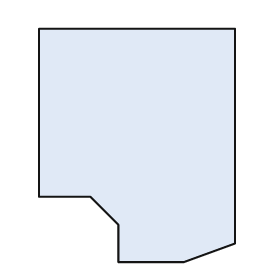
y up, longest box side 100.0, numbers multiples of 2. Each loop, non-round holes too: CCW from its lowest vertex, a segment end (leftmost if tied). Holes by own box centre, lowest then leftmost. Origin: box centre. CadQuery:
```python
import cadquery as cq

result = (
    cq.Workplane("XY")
    .moveTo(-8.0, -50.0)
    .lineTo(20.0, -50.0)
    .lineTo(42.0, -42.0)
    .lineTo(42.0, 50.0)
    .lineTo(-42.0, 50.0)
    .lineTo(-42.0, -22.0)
    .lineTo(-20.0, -22.0)
    .lineTo(-8.0, -34.0)
    .close()
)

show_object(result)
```